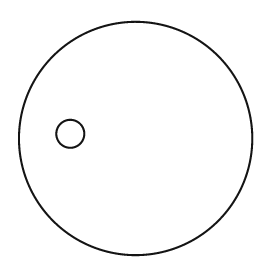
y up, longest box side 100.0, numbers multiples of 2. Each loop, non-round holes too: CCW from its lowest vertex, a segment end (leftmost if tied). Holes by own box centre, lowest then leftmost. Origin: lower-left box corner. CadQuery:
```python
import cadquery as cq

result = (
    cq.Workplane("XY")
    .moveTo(50.0, 50.0)
    .circle(50.0)
    .moveTo(22.0, 52.0)
    .circle(6.0)
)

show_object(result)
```